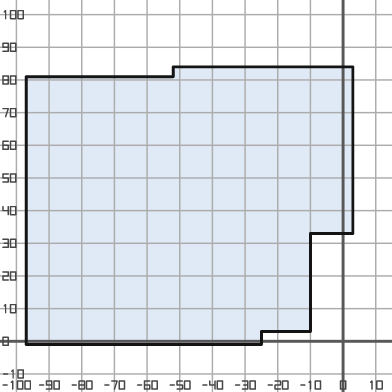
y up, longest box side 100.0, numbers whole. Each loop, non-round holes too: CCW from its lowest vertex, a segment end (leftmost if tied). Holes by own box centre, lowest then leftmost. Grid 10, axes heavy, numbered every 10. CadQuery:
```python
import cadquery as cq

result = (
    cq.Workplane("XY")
    .moveTo(-97.0, -1.0)
    .lineTo(-25.0, -1.0)
    .lineTo(-25.0, 3.0)
    .lineTo(-10.0, 3.0)
    .lineTo(-10.0, 33.0)
    .lineTo(3.0, 33.0)
    .lineTo(3.0, 84.0)
    .lineTo(-52.0, 84.0)
    .lineTo(-52.0, 81.0)
    .lineTo(-97.0, 81.0)
    .close()
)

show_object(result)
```